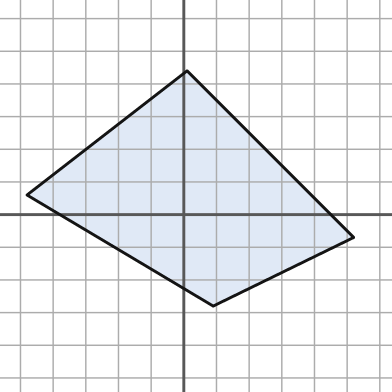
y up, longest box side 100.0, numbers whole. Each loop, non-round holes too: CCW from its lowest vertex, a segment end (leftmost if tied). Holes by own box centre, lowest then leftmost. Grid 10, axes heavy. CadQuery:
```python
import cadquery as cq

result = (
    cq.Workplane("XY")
    .moveTo(9.0, -28.0)
    .lineTo(52.0, -7.0)
    .lineTo(1.0, 44.0)
    .lineTo(-48.0, 6.0)
    .close()
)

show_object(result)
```